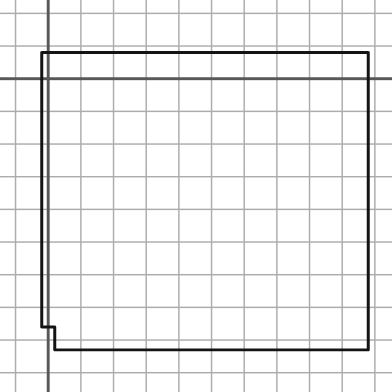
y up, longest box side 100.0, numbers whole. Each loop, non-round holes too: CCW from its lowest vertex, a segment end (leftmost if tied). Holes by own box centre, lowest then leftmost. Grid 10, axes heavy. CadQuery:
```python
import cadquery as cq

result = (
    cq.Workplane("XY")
    .moveTo(2.0, -83.0)
    .lineTo(98.0, -83.0)
    .lineTo(98.0, 8.0)
    .lineTo(-2.0, 8.0)
    .lineTo(-2.0, -76.0)
    .lineTo(2.0, -76.0)
    .close()
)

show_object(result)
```